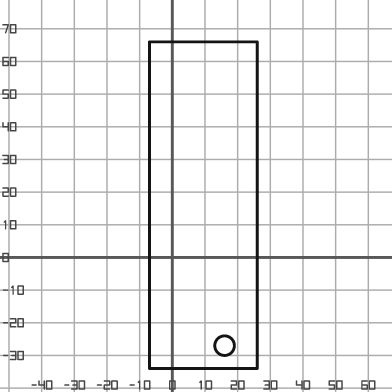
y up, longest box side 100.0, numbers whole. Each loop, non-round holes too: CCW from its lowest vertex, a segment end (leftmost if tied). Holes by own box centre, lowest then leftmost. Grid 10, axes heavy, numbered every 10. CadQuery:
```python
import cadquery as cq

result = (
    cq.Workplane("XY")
    .moveTo(-7.0, -34.0)
    .lineTo(26.0, -34.0)
    .lineTo(26.0, 66.0)
    .lineTo(-7.0, 66.0)
    .close()
    .moveTo(16.0, -27.0)
    .circle(3.0)
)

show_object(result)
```